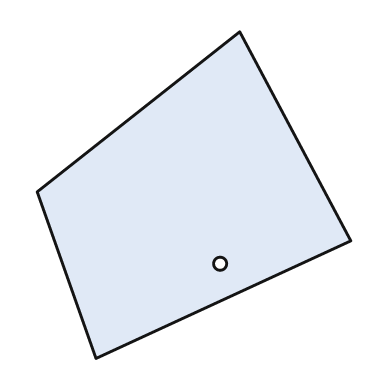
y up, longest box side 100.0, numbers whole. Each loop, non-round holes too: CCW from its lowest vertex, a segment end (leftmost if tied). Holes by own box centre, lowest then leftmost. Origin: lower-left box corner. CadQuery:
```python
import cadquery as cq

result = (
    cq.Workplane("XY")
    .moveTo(18.0, 0.0)
    .lineTo(96.0, 36.0)
    .lineTo(62.0, 100.0)
    .lineTo(0.0, 51.0)
    .close()
    .moveTo(56.0, 29.0)
    .circle(2.0)
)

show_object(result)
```